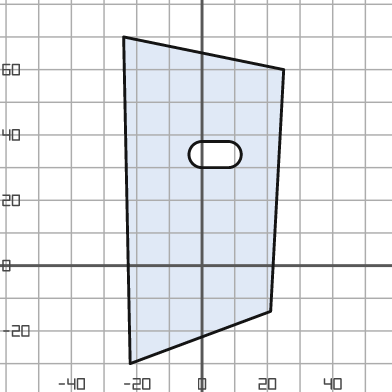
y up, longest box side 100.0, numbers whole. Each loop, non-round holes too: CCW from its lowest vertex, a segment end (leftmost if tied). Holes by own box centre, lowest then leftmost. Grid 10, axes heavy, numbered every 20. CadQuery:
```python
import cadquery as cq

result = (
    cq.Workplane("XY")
    .moveTo(-22.0, -30.0)
    .lineTo(21.0, -14.0)
    .lineTo(25.0, 60.0)
    .lineTo(-24.0, 70.0)
    .close()
    .moveTo(0.0, 30.0)
    .lineTo(8.0, 30.0)
    .threePointArc((12.0, 34.0), (8.0, 38.0))
    .lineTo(0.0, 38.0)
    .threePointArc((-4.0, 34.0), (0.0, 30.0))
    .close()
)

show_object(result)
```